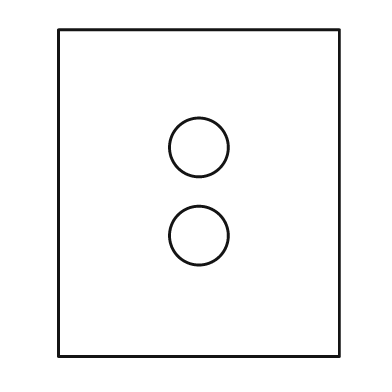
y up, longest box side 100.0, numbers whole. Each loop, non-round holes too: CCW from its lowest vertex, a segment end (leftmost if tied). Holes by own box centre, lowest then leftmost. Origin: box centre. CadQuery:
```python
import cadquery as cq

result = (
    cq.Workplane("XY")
    .moveTo(-43.0, -50.0)
    .lineTo(43.0, -50.0)
    .lineTo(43.0, 50.0)
    .lineTo(-43.0, 50.0)
    .close()
    .moveTo(0.0, -13.0)
    .circle(9.0)
    .moveTo(0.0, 14.0)
    .circle(9.0)
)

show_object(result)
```